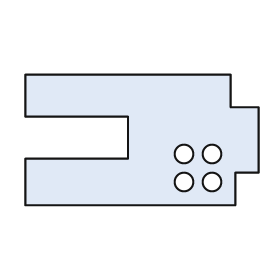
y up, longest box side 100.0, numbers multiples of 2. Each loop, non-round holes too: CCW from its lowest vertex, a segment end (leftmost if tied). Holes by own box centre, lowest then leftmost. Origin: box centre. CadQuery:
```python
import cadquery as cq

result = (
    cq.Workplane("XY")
    .moveTo(-50.0, -28.0)
    .lineTo(40.0, -28.0)
    .lineTo(40.0, -14.0)
    .lineTo(50.0, -14.0)
    .lineTo(50.0, 14.0)
    .lineTo(38.0, 14.0)
    .lineTo(38.0, 28.0)
    .lineTo(-50.0, 28.0)
    .lineTo(-50.0, 10.0)
    .lineTo(-6.0, 10.0)
    .lineTo(-6.0, -8.0)
    .lineTo(-50.0, -8.0)
    .close()
    .moveTo(18.0, -18.0)
    .circle(4.0)
    .moveTo(30.0, -18.0)
    .circle(4.0)
    .moveTo(18.0, -6.0)
    .circle(4.0)
    .moveTo(30.0, -6.0)
    .circle(4.0)
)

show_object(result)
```